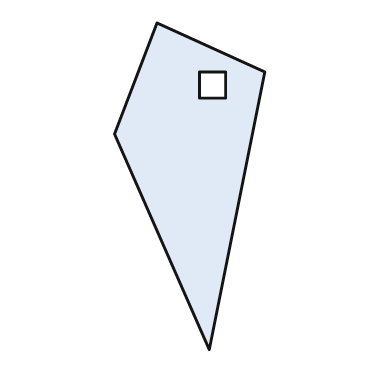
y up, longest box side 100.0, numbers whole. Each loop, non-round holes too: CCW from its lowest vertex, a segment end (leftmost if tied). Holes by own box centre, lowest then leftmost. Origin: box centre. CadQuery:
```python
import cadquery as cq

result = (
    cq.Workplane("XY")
    .moveTo(6.0, -50.0)
    .lineTo(23.0, 35.0)
    .lineTo(-10.0, 50.0)
    .lineTo(-23.0, 16.0)
    .close()
    .moveTo(3.0, 27.0)
    .lineTo(11.0, 27.0)
    .lineTo(11.0, 35.0)
    .lineTo(3.0, 35.0)
    .close()
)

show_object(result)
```